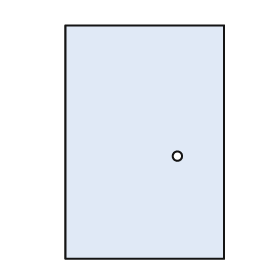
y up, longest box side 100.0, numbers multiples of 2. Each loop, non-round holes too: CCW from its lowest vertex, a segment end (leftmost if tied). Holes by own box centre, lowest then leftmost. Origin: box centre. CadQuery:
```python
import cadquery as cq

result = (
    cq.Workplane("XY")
    .moveTo(-34.0, -50.0)
    .lineTo(34.0, -50.0)
    .lineTo(34.0, 50.0)
    .lineTo(-34.0, 50.0)
    .close()
    .moveTo(14.0, -6.0)
    .circle(2.0)
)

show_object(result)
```